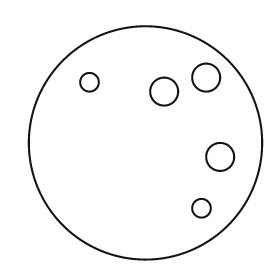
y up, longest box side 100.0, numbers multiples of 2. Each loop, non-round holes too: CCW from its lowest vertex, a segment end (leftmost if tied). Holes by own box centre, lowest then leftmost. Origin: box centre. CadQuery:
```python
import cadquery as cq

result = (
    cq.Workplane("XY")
    .moveTo(0.0, 0.0)
    .circle(50.0)
    .moveTo(24.0, -28.0)
    .circle(4.0)
    .moveTo(32.0, -6.0)
    .circle(6.0)
    .moveTo(8.0, 22.0)
    .circle(6.0)
    .moveTo(-24.0, 26.0)
    .circle(4.0)
    .moveTo(26.0, 28.0)
    .circle(6.0)
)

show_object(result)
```